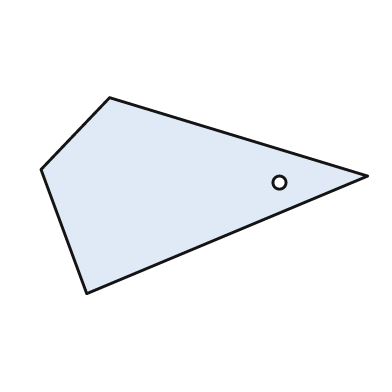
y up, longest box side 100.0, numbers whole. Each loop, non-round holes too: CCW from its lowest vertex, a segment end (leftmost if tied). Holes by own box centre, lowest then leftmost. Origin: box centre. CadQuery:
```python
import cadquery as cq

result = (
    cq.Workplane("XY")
    .moveTo(-36.0, -30.0)
    .lineTo(50.0, 6.0)
    .lineTo(-29.0, 30.0)
    .lineTo(-50.0, 8.0)
    .close()
    .moveTo(23.0, 4.0)
    .circle(2.0)
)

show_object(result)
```